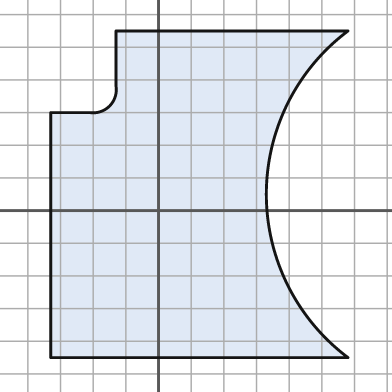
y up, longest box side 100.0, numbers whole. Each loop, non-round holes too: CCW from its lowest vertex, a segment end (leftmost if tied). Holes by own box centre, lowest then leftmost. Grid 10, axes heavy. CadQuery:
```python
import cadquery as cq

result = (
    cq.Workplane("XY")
    .moveTo(-33.0, -45.0)
    .lineTo(58.0, -45.0)
    .threePointArc((33.0, 5.0), (58.0, 55.0))
    .lineTo(-13.0, 55.0)
    .lineTo(-13.0, 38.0)
    .threePointArc((-15.0, 32.0), (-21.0, 30.0))
    .lineTo(-33.0, 30.0)
    .close()
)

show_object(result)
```